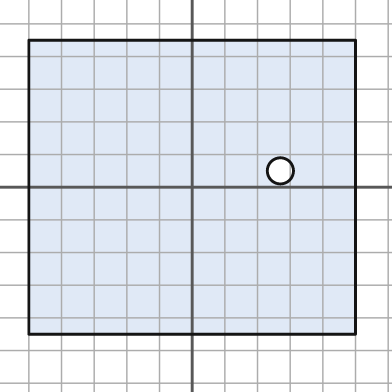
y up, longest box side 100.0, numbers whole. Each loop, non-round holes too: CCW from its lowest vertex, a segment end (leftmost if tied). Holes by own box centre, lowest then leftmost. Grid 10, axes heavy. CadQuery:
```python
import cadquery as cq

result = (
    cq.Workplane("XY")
    .moveTo(-50.0, -45.0)
    .lineTo(50.0, -45.0)
    .lineTo(50.0, 45.0)
    .lineTo(-50.0, 45.0)
    .close()
    .moveTo(27.0, 5.0)
    .circle(4.0)
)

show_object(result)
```